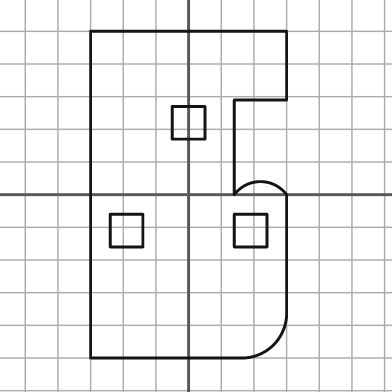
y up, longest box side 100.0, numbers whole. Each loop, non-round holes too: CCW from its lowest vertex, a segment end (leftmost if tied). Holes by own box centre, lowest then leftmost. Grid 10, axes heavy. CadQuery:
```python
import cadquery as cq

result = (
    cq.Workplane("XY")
    .moveTo(-30.0, -50.0)
    .lineTo(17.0, -50.0)
    .threePointArc((26.0, -46.0), (30.0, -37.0))
    .lineTo(30.0, 0.0)
    .threePointArc((22.0, 4.0), (14.0, 0.0))
    .lineTo(14.0, 29.0)
    .lineTo(30.0, 29.0)
    .lineTo(30.0, 50.0)
    .lineTo(-30.0, 50.0)
    .close()
    .moveTo(-24.0, -16.0)
    .lineTo(-14.0, -16.0)
    .lineTo(-14.0, -6.0)
    .lineTo(-24.0, -6.0)
    .close()
    .moveTo(14.0, -16.0)
    .lineTo(24.0, -16.0)
    .lineTo(24.0, -6.0)
    .lineTo(14.0, -6.0)
    .close()
    .moveTo(-5.0, 17.0)
    .lineTo(5.0, 17.0)
    .lineTo(5.0, 27.0)
    .lineTo(-5.0, 27.0)
    .close()
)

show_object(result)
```